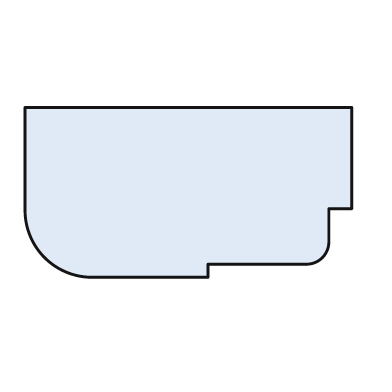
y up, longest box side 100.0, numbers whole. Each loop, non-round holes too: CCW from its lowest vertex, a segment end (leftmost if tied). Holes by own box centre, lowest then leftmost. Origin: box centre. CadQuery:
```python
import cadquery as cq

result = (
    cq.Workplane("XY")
    .moveTo(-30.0, -26.0)
    .lineTo(6.0, -26.0)
    .lineTo(6.0, -22.0)
    .lineTo(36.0, -22.0)
    .threePointArc((41.0, -20.0), (43.0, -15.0))
    .lineTo(43.0, -5.0)
    .lineTo(50.0, -5.0)
    .lineTo(50.0, 26.0)
    .lineTo(-50.0, 26.0)
    .lineTo(-50.0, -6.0)
    .threePointArc((-44.0, -20.0), (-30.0, -26.0))
    .close()
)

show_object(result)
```